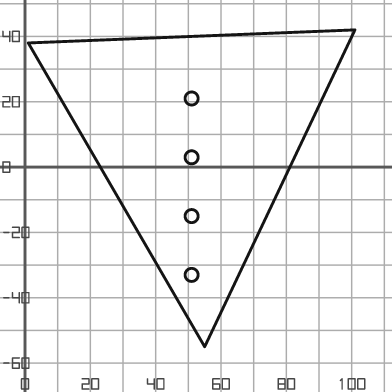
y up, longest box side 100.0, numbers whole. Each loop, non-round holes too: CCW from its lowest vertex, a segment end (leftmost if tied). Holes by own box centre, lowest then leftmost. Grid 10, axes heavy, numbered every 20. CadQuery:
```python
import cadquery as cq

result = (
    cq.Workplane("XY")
    .moveTo(55.0, -55.0)
    .lineTo(101.0, 42.0)
    .lineTo(1.0, 38.0)
    .close()
    .moveTo(51.0, -33.0)
    .circle(2.0)
    .moveTo(51.0, -15.0)
    .circle(2.0)
    .moveTo(51.0, 3.0)
    .circle(2.0)
    .moveTo(51.0, 21.0)
    .circle(2.0)
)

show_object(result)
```